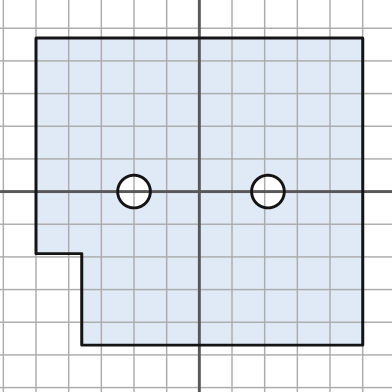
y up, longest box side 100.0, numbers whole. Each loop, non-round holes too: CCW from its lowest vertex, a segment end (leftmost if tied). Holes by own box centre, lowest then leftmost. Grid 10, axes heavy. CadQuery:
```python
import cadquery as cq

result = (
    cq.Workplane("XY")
    .moveTo(-36.0, -47.0)
    .lineTo(50.0, -47.0)
    .lineTo(50.0, 47.0)
    .lineTo(-50.0, 47.0)
    .lineTo(-50.0, -19.0)
    .lineTo(-36.0, -19.0)
    .close()
    .moveTo(-20.0, 0.0)
    .circle(5.0)
    .moveTo(21.0, 0.0)
    .circle(5.0)
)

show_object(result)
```